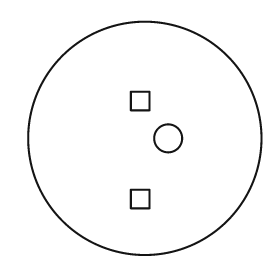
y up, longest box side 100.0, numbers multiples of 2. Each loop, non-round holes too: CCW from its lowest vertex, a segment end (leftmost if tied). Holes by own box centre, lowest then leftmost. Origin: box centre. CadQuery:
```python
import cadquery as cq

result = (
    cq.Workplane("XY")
    .moveTo(0.0, 0.0)
    .circle(50.0)
    .moveTo(-6.0, -30.0)
    .lineTo(2.0, -30.0)
    .lineTo(2.0, -22.0)
    .lineTo(-6.0, -22.0)
    .close()
    .moveTo(10.0, 0.0)
    .circle(6.0)
    .moveTo(-6.0, 12.0)
    .lineTo(2.0, 12.0)
    .lineTo(2.0, 20.0)
    .lineTo(-6.0, 20.0)
    .close()
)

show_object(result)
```